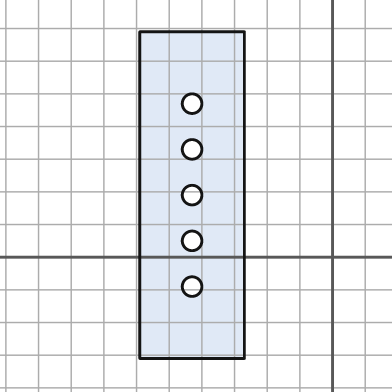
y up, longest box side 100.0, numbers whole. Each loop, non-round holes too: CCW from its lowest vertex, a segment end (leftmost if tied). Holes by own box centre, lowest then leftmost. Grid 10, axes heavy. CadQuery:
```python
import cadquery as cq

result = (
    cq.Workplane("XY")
    .moveTo(-59.0, -31.0)
    .lineTo(-27.0, -31.0)
    .lineTo(-27.0, 69.0)
    .lineTo(-59.0, 69.0)
    .close()
    .moveTo(-43.0, -9.0)
    .circle(3.0)
    .moveTo(-43.0, 5.0)
    .circle(3.0)
    .moveTo(-43.0, 19.0)
    .circle(3.0)
    .moveTo(-43.0, 33.0)
    .circle(3.0)
    .moveTo(-43.0, 47.0)
    .circle(3.0)
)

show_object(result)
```